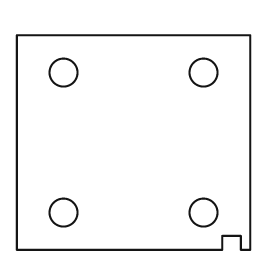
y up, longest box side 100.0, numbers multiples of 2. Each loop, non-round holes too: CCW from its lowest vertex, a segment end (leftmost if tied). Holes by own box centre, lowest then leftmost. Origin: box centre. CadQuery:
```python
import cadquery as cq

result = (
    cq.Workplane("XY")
    .moveTo(-50.0, -46.0)
    .lineTo(38.0, -46.0)
    .lineTo(38.0, -40.0)
    .lineTo(46.0, -40.0)
    .lineTo(46.0, -46.0)
    .lineTo(50.0, -46.0)
    .lineTo(50.0, 46.0)
    .lineTo(-50.0, 46.0)
    .close()
    .moveTo(-30.0, -30.0)
    .circle(6.0)
    .moveTo(30.0, -30.0)
    .circle(6.0)
    .moveTo(-30.0, 30.0)
    .circle(6.0)
    .moveTo(30.0, 30.0)
    .circle(6.0)
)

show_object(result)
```